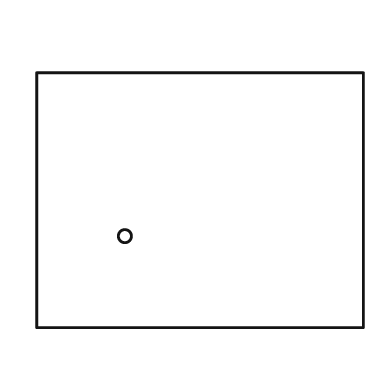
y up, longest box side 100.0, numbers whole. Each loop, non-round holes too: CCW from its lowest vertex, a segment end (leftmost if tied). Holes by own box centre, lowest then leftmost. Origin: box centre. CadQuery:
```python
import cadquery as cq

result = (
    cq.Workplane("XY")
    .moveTo(-50.0, -39.0)
    .lineTo(50.0, -39.0)
    .lineTo(50.0, 39.0)
    .lineTo(-50.0, 39.0)
    .close()
    .moveTo(-23.0, -11.0)
    .circle(2.0)
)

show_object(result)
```